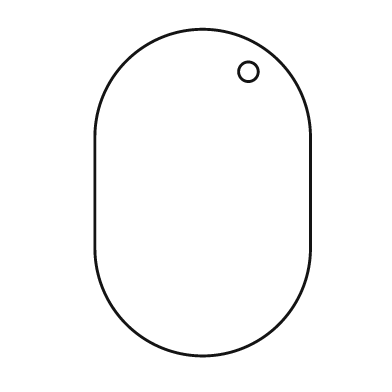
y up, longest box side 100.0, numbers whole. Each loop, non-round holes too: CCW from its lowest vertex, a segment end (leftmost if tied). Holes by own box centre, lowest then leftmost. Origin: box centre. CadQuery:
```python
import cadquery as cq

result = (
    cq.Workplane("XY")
    .moveTo(-33.0, -17.0)
    .threePointArc((0.0, -50.0), (33.0, -17.0))
    .lineTo(33.0, 17.0)
    .threePointArc((0.0, 50.0), (-33.0, 17.0))
    .close()
    .moveTo(14.0, 37.0)
    .circle(3.0)
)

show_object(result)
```